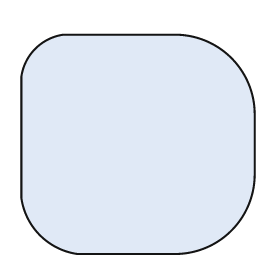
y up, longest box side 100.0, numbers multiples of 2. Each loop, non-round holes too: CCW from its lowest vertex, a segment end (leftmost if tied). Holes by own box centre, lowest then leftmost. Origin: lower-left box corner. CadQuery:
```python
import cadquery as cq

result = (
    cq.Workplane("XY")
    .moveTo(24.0, 0.0)
    .lineTo(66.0, 0.0)
    .threePointArc((90.0, 10.0), (100.0, 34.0))
    .lineTo(100.0, 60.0)
    .threePointArc((90.0, 84.0), (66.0, 94.0))
    .lineTo(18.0, 94.0)
    .threePointArc((6.0, 88.0), (0.0, 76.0))
    .lineTo(0.0, 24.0)
    .threePointArc((8.0, 8.0), (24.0, 0.0))
    .close()
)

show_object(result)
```